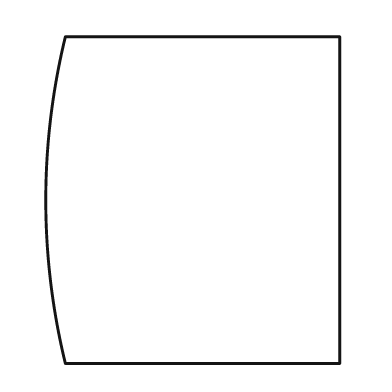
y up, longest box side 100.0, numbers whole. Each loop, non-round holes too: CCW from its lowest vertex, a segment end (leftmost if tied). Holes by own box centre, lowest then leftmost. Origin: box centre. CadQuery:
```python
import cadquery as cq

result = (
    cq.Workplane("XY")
    .moveTo(-39.0, -50.0)
    .lineTo(45.0, -50.0)
    .lineTo(45.0, 50.0)
    .lineTo(-39.0, 50.0)
    .threePointArc((-45.0, 0.0), (-39.0, -50.0))
    .close()
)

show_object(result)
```